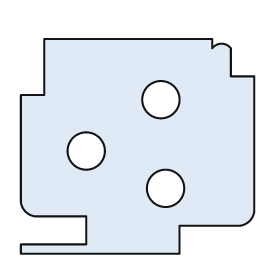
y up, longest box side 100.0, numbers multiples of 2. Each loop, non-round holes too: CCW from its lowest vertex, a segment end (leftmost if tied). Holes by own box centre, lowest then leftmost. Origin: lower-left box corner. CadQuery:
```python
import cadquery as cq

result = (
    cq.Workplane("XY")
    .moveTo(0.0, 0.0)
    .lineTo(68.0, 0.0)
    .lineTo(68.0, 12.0)
    .lineTo(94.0, 12.0)
    .threePointArc((98.0, 14.0), (100.0, 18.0))
    .lineTo(100.0, 76.0)
    .lineTo(90.0, 76.0)
    .lineTo(90.0, 88.0)
    .threePointArc((86.0, 90.0), (82.0, 88.0))
    .lineTo(82.0, 92.0)
    .lineTo(10.0, 92.0)
    .lineTo(10.0, 68.0)
    .lineTo(0.0, 68.0)
    .lineTo(0.0, 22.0)
    .threePointArc((2.0, 18.0), (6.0, 16.0))
    .lineTo(28.0, 16.0)
    .lineTo(28.0, 4.0)
    .lineTo(0.0, 4.0)
    .close()
    .moveTo(62.0, 28.0)
    .circle(8.0)
    .moveTo(28.0, 44.0)
    .circle(8.0)
    .moveTo(60.0, 66.0)
    .circle(8.0)
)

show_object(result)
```